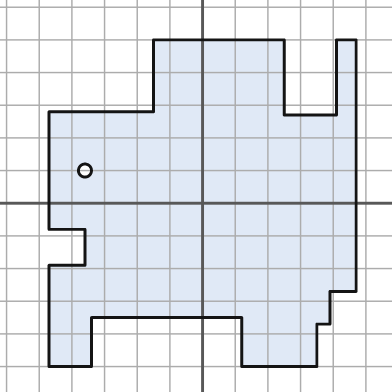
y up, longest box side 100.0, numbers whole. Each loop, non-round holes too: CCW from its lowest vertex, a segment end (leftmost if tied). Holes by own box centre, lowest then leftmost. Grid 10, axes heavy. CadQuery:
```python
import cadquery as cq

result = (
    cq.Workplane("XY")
    .moveTo(-47.0, -50.0)
    .lineTo(-34.0, -50.0)
    .lineTo(-34.0, -35.0)
    .lineTo(12.0, -35.0)
    .lineTo(12.0, -50.0)
    .lineTo(35.0, -50.0)
    .lineTo(35.0, -37.0)
    .lineTo(39.0, -37.0)
    .lineTo(39.0, -27.0)
    .lineTo(47.0, -27.0)
    .lineTo(47.0, 50.0)
    .lineTo(41.0, 50.0)
    .lineTo(41.0, 27.0)
    .lineTo(25.0, 27.0)
    .lineTo(25.0, 50.0)
    .lineTo(-15.0, 50.0)
    .lineTo(-15.0, 28.0)
    .lineTo(-47.0, 28.0)
    .lineTo(-47.0, -8.0)
    .lineTo(-36.0, -8.0)
    .lineTo(-36.0, -19.0)
    .lineTo(-47.0, -19.0)
    .close()
    .moveTo(-36.0, 10.0)
    .circle(2.0)
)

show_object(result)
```